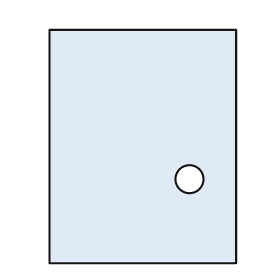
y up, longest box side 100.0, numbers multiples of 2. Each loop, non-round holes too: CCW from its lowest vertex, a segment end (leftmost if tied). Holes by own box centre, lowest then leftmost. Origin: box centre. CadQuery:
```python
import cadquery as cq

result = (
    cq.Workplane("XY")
    .moveTo(-40.0, -50.0)
    .lineTo(40.0, -50.0)
    .lineTo(40.0, 50.0)
    .lineTo(-40.0, 50.0)
    .close()
    .moveTo(20.0, -14.0)
    .circle(6.0)
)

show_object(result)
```